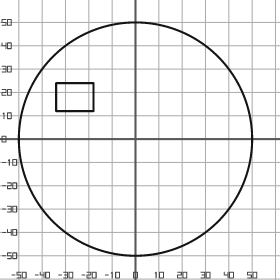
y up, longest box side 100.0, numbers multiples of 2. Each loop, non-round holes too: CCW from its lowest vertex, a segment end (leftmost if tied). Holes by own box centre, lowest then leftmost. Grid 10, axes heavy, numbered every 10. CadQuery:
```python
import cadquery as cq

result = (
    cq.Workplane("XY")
    .moveTo(0.0, 0.0)
    .circle(50.0)
    .moveTo(-34.0, 12.0)
    .lineTo(-18.0, 12.0)
    .lineTo(-18.0, 24.0)
    .lineTo(-34.0, 24.0)
    .close()
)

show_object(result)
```